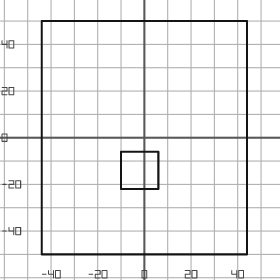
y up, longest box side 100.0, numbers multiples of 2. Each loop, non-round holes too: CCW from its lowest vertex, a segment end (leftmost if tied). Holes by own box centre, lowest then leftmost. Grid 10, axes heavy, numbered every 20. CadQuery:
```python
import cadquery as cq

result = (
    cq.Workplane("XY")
    .moveTo(-44.0, -50.0)
    .lineTo(44.0, -50.0)
    .lineTo(44.0, 50.0)
    .lineTo(-44.0, 50.0)
    .close()
    .moveTo(-10.0, -22.0)
    .lineTo(6.0, -22.0)
    .lineTo(6.0, -6.0)
    .lineTo(-10.0, -6.0)
    .close()
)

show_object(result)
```